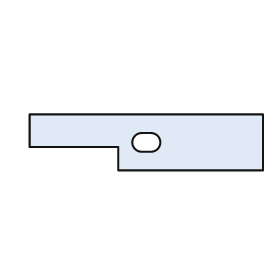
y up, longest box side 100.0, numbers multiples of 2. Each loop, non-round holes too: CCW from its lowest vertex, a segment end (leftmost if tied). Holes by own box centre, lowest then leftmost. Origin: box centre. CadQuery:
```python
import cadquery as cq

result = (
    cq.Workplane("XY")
    .moveTo(-12.0, -12.0)
    .lineTo(50.0, -12.0)
    .lineTo(50.0, 12.0)
    .lineTo(-50.0, 12.0)
    .lineTo(-50.0, -2.0)
    .lineTo(-12.0, -2.0)
    .close()
    .moveTo(-2.0, -4.0)
    .lineTo(2.0, -4.0)
    .threePointArc((6.0, 0.0), (2.0, 4.0))
    .lineTo(-2.0, 4.0)
    .threePointArc((-6.0, 0.0), (-2.0, -4.0))
    .close()
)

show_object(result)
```